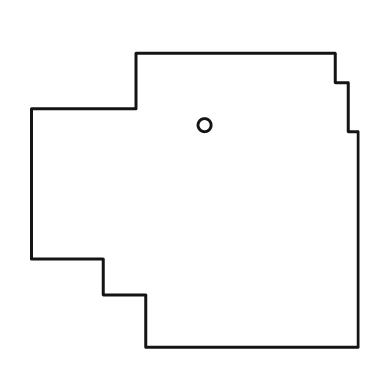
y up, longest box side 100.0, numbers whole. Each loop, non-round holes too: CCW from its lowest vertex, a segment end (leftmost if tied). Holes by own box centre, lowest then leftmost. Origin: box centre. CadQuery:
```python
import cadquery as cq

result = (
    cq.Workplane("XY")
    .moveTo(-15.0, -45.0)
    .lineTo(50.0, -45.0)
    .lineTo(50.0, 21.0)
    .lineTo(47.0, 21.0)
    .lineTo(47.0, 36.0)
    .lineTo(43.0, 36.0)
    .lineTo(43.0, 45.0)
    .lineTo(-18.0, 45.0)
    .lineTo(-18.0, 28.0)
    .lineTo(-50.0, 28.0)
    .lineTo(-50.0, -18.0)
    .lineTo(-28.0, -18.0)
    .lineTo(-28.0, -29.0)
    .lineTo(-15.0, -29.0)
    .close()
    .moveTo(3.0, 23.0)
    .circle(2.0)
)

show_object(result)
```